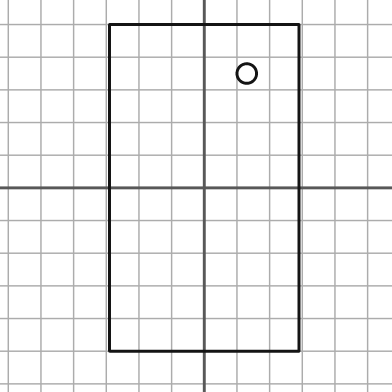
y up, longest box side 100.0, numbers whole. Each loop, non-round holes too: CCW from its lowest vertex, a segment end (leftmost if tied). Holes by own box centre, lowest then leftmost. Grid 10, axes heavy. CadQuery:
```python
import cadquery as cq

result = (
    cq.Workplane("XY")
    .moveTo(-29.0, -50.0)
    .lineTo(29.0, -50.0)
    .lineTo(29.0, 50.0)
    .lineTo(-29.0, 50.0)
    .close()
    .moveTo(13.0, 35.0)
    .circle(3.0)
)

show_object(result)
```